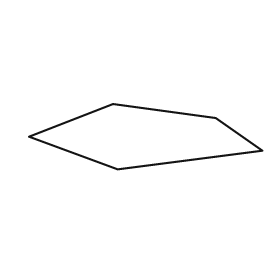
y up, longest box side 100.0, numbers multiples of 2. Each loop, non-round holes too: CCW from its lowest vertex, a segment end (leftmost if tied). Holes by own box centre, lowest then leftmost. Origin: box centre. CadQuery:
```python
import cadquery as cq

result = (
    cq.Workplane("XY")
    .moveTo(-12.0, -14.0)
    .lineTo(50.0, -6.0)
    .lineTo(30.0, 8.0)
    .lineTo(-14.0, 14.0)
    .lineTo(-50.0, 0.0)
    .close()
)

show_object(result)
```